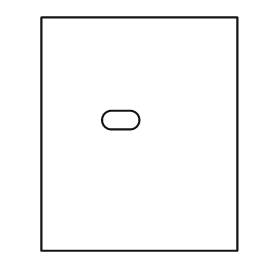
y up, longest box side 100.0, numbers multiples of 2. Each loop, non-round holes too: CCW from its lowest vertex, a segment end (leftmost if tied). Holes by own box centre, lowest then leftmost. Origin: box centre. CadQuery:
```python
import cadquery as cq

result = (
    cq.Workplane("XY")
    .moveTo(-42.0, -50.0)
    .lineTo(42.0, -50.0)
    .lineTo(42.0, 50.0)
    .lineTo(-42.0, 50.0)
    .close()
    .moveTo(-12.0, 2.0)
    .lineTo(-4.0, 2.0)
    .threePointArc((0.0, 6.0), (-4.0, 10.0))
    .lineTo(-12.0, 10.0)
    .threePointArc((-16.0, 6.0), (-12.0, 2.0))
    .close()
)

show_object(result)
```